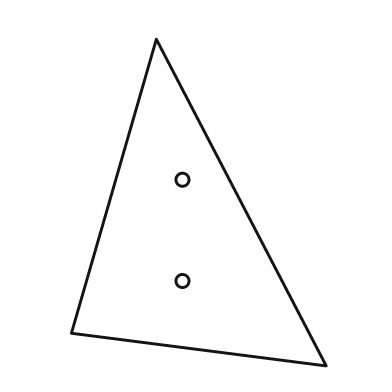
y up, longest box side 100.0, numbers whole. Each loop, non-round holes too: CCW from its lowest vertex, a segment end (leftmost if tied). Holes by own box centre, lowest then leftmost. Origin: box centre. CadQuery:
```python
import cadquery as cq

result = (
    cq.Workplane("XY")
    .moveTo(39.0, -50.0)
    .lineTo(-13.0, 50.0)
    .lineTo(-39.0, -40.0)
    .close()
    .moveTo(-5.0, -24.0)
    .circle(2.0)
    .moveTo(-5.0, 7.0)
    .circle(2.0)
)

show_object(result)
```